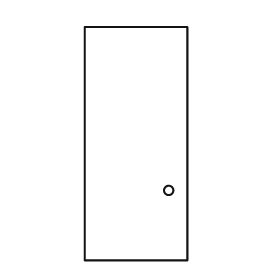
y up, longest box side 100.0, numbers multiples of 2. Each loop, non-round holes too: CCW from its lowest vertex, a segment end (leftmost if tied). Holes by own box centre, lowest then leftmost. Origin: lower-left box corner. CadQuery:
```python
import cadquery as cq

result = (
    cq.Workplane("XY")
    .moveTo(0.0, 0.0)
    .lineTo(44.0, 0.0)
    .lineTo(44.0, 100.0)
    .lineTo(0.0, 100.0)
    .close()
    .moveTo(36.0, 30.0)
    .circle(2.0)
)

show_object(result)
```